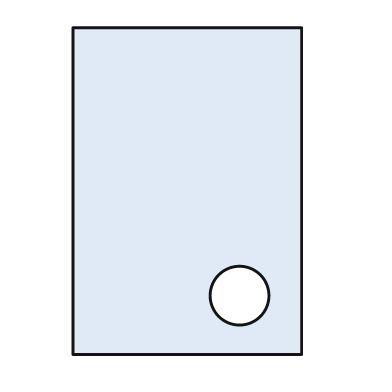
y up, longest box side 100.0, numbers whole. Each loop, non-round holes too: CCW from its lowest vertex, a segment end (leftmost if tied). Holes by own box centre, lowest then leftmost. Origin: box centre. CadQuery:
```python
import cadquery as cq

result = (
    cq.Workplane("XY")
    .moveTo(-35.0, -50.0)
    .lineTo(35.0, -50.0)
    .lineTo(35.0, 50.0)
    .lineTo(-35.0, 50.0)
    .close()
    .moveTo(16.0, -32.0)
    .circle(9.0)
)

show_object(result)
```